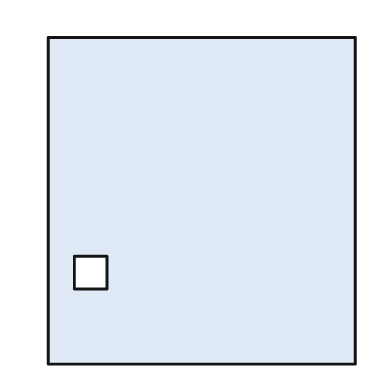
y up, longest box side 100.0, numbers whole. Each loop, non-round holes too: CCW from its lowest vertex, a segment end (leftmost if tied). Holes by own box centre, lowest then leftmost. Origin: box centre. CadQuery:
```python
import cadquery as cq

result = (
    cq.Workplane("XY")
    .moveTo(-47.0, -50.0)
    .lineTo(47.0, -50.0)
    .lineTo(47.0, 50.0)
    .lineTo(-47.0, 50.0)
    .close()
    .moveTo(-39.0, -27.0)
    .lineTo(-29.0, -27.0)
    .lineTo(-29.0, -17.0)
    .lineTo(-39.0, -17.0)
    .close()
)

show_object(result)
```